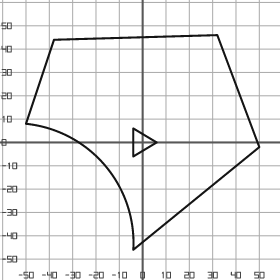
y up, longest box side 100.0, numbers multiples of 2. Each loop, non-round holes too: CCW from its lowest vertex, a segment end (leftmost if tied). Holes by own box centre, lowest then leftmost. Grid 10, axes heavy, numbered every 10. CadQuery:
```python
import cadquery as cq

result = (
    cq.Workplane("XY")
    .moveTo(-4.0, -46.0)
    .lineTo(50.0, -2.0)
    .lineTo(32.0, 46.0)
    .lineTo(-38.0, 44.0)
    .lineTo(-50.0, 8.0)
    .threePointArc((-16.0, -10.0), (-4.0, -46.0))
    .close()
    .moveTo(-4.0, -6.0)
    .lineTo(6.0, 0.0)
    .lineTo(-4.0, 6.0)
    .close()
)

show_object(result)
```